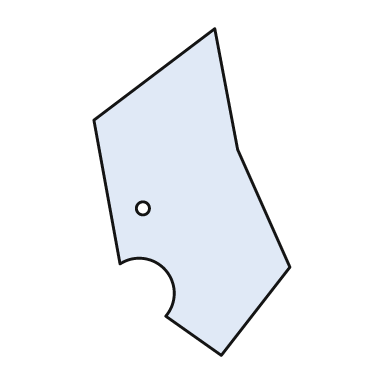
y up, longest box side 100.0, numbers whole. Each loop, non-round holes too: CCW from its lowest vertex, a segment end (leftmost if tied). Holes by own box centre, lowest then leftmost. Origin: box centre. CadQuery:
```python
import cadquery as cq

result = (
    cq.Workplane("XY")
    .moveTo(9.0, -50.0)
    .lineTo(30.0, -23.0)
    .lineTo(14.0, 13.0)
    .lineTo(7.0, 50.0)
    .lineTo(-30.0, 22.0)
    .lineTo(-22.0, -22.0)
    .threePointArc((-8.0, -24.0), (-8.0, -38.0))
    .close()
    .moveTo(-15.0, -5.0)
    .circle(2.0)
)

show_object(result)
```